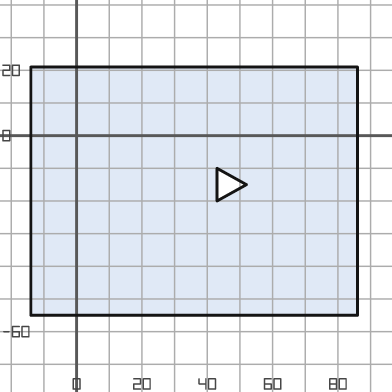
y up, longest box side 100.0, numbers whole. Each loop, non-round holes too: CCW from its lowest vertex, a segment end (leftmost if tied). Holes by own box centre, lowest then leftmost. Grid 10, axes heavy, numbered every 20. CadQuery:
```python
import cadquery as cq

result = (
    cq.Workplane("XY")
    .moveTo(-14.0, -55.0)
    .lineTo(86.0, -55.0)
    .lineTo(86.0, 21.0)
    .lineTo(-14.0, 21.0)
    .close()
    .moveTo(43.0, -20.0)
    .lineTo(52.0, -15.0)
    .lineTo(43.0, -10.0)
    .close()
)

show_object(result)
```